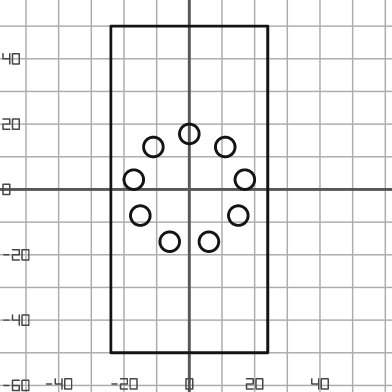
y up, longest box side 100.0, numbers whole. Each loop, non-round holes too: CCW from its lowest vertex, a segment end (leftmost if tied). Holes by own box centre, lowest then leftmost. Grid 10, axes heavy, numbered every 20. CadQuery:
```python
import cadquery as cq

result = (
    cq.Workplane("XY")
    .moveTo(-24.0, -50.0)
    .lineTo(24.0, -50.0)
    .lineTo(24.0, 50.0)
    .lineTo(-24.0, 50.0)
    .close()
    .moveTo(-6.0, -16.0)
    .circle(3.0)
    .moveTo(6.0, -16.0)
    .circle(3.0)
    .moveTo(-15.0, -8.0)
    .circle(3.0)
    .moveTo(15.0, -8.0)
    .circle(3.0)
    .moveTo(-17.0, 3.0)
    .circle(3.0)
    .moveTo(17.0, 3.0)
    .circle(3.0)
    .moveTo(-11.0, 13.0)
    .circle(3.0)
    .moveTo(11.0, 13.0)
    .circle(3.0)
    .moveTo(0.0, 17.0)
    .circle(3.0)
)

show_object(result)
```